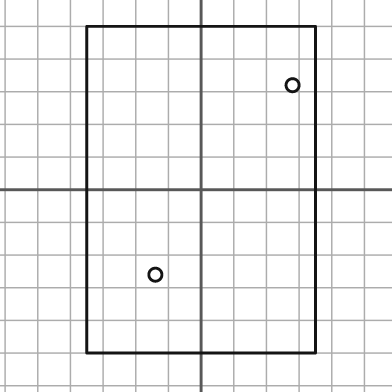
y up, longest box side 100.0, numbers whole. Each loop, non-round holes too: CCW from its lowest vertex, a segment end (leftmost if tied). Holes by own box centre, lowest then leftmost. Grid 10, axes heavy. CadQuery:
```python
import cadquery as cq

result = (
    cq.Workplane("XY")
    .moveTo(-35.0, -50.0)
    .lineTo(35.0, -50.0)
    .lineTo(35.0, 50.0)
    .lineTo(-35.0, 50.0)
    .close()
    .moveTo(-14.0, -26.0)
    .circle(2.0)
    .moveTo(28.0, 32.0)
    .circle(2.0)
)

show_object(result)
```